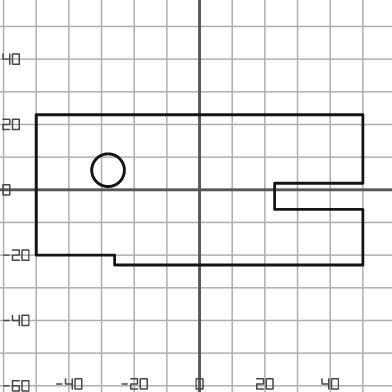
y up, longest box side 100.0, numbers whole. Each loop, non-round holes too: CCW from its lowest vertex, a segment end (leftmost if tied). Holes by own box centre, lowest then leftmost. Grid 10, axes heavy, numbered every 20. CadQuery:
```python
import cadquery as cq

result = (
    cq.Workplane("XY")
    .moveTo(-26.0, -23.0)
    .lineTo(50.0, -23.0)
    .lineTo(50.0, -6.0)
    .lineTo(23.0, -6.0)
    .lineTo(23.0, 2.0)
    .lineTo(50.0, 2.0)
    .lineTo(50.0, 23.0)
    .lineTo(-50.0, 23.0)
    .lineTo(-50.0, -20.0)
    .lineTo(-26.0, -20.0)
    .close()
    .moveTo(-28.0, 6.0)
    .circle(5.0)
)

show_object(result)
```